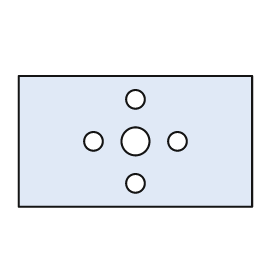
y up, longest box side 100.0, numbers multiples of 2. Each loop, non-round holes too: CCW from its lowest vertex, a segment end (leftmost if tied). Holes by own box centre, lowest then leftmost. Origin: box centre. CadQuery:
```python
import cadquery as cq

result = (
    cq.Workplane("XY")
    .moveTo(-50.0, -28.0)
    .lineTo(50.0, -28.0)
    .lineTo(50.0, 28.0)
    .lineTo(-50.0, 28.0)
    .close()
    .moveTo(0.0, -18.0)
    .circle(4.0)
    .moveTo(-18.0, 0.0)
    .circle(4.0)
    .moveTo(0.0, 0.0)
    .circle(6.0)
    .moveTo(18.0, 0.0)
    .circle(4.0)
    .moveTo(0.0, 18.0)
    .circle(4.0)
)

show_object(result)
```